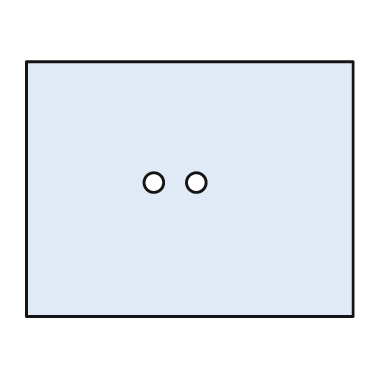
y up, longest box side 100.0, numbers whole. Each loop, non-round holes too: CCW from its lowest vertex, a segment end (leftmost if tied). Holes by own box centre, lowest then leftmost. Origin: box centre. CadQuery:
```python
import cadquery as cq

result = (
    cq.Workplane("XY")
    .moveTo(-50.0, -39.0)
    .lineTo(50.0, -39.0)
    .lineTo(50.0, 39.0)
    .lineTo(-50.0, 39.0)
    .close()
    .moveTo(-11.0, 2.0)
    .circle(3.0)
    .moveTo(2.0, 2.0)
    .circle(3.0)
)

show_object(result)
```